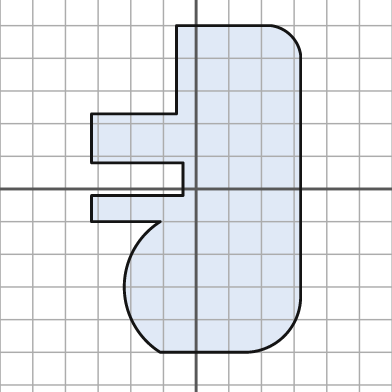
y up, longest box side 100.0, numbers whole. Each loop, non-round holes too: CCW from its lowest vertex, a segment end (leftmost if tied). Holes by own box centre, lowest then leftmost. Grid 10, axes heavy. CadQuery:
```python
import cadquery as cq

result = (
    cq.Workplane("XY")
    .moveTo(-11.0, -50.0)
    .lineTo(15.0, -50.0)
    .threePointArc((27.0, -45.0), (32.0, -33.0))
    .lineTo(32.0, 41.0)
    .threePointArc((29.0, 47.0), (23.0, 50.0))
    .lineTo(-6.0, 50.0)
    .lineTo(-6.0, 23.0)
    .lineTo(-32.0, 23.0)
    .lineTo(-32.0, 8.0)
    .lineTo(-4.0, 8.0)
    .lineTo(-4.0, -2.0)
    .lineTo(-32.0, -2.0)
    .lineTo(-32.0, -10.0)
    .lineTo(-11.0, -10.0)
    .threePointArc((-22.0, -30.0), (-11.0, -50.0))
    .close()
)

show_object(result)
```